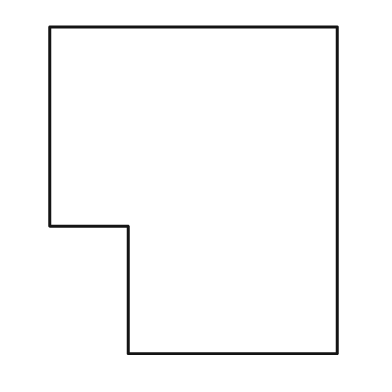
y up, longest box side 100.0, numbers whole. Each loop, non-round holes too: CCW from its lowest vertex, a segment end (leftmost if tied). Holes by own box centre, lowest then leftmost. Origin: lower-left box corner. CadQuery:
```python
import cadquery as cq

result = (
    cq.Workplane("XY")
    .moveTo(24.0, 0.0)
    .lineTo(88.0, 0.0)
    .lineTo(88.0, 100.0)
    .lineTo(0.0, 100.0)
    .lineTo(0.0, 39.0)
    .lineTo(24.0, 39.0)
    .close()
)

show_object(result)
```